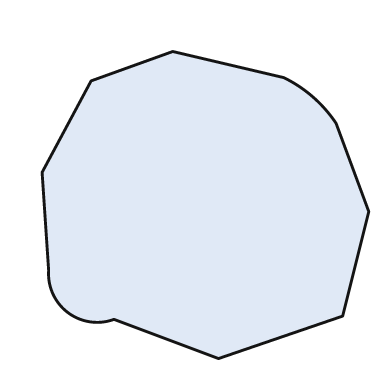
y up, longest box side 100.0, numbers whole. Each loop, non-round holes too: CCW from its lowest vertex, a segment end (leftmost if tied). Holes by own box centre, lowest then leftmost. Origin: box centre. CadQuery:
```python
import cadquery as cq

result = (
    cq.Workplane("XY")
    .moveTo(4.0, -47.0)
    .lineTo(42.0, -34.0)
    .lineTo(50.0, -2.0)
    .lineTo(40.0, 25.0)
    .threePointArc((33.0, 33.0), (24.0, 39.0))
    .lineTo(-10.0, 47.0)
    .lineTo(-35.0, 38.0)
    .lineTo(-50.0, 10.0)
    .lineTo(-48.0, -20.0)
    .threePointArc((-42.0, -33.0), (-28.0, -35.0))
    .close()
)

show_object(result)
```